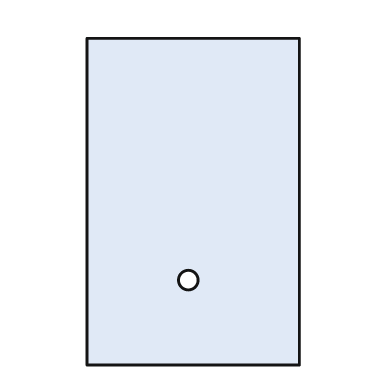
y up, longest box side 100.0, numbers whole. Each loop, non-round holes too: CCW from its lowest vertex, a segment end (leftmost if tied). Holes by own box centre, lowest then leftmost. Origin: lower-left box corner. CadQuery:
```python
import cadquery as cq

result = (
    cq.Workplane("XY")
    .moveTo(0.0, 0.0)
    .lineTo(65.0, 0.0)
    .lineTo(65.0, 100.0)
    .lineTo(0.0, 100.0)
    .close()
    .moveTo(31.0, 26.0)
    .circle(3.0)
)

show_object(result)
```